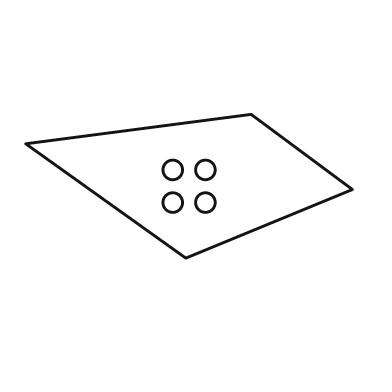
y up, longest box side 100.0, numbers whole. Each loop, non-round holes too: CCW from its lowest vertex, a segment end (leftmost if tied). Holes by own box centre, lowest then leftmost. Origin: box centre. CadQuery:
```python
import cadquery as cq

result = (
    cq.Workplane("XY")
    .moveTo(-1.0, -22.0)
    .lineTo(50.0, -1.0)
    .lineTo(19.0, 22.0)
    .lineTo(-50.0, 13.0)
    .close()
    .moveTo(-5.0, -5.0)
    .circle(3.0)
    .moveTo(5.0, -5.0)
    .circle(3.0)
    .moveTo(-5.0, 5.0)
    .circle(3.0)
    .moveTo(5.0, 5.0)
    .circle(3.0)
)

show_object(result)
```